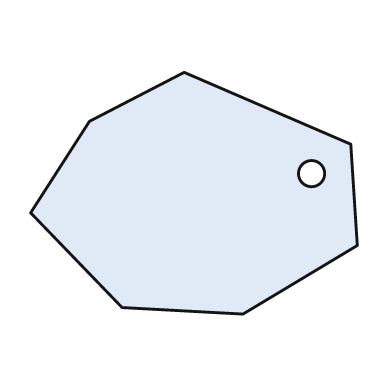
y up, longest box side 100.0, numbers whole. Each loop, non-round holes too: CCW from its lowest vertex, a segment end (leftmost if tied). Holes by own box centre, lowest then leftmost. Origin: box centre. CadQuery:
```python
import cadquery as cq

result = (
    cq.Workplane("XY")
    .moveTo(15.0, -37.0)
    .lineTo(50.0, -16.0)
    .lineTo(48.0, 15.0)
    .lineTo(-3.0, 37.0)
    .lineTo(-32.0, 22.0)
    .lineTo(-50.0, -6.0)
    .lineTo(-22.0, -35.0)
    .close()
    .moveTo(36.0, 6.0)
    .circle(4.0)
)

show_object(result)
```